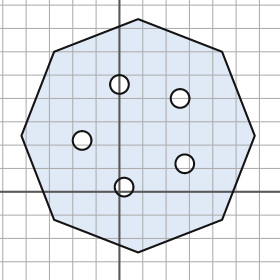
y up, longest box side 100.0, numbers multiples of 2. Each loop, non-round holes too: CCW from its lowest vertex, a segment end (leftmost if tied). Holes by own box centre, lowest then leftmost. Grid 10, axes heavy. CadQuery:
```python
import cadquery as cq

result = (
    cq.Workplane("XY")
    .moveTo(8.0, -26.0)
    .lineTo(44.0, -12.0)
    .lineTo(58.0, 24.0)
    .lineTo(44.0, 60.0)
    .lineTo(8.0, 74.0)
    .lineTo(-28.0, 60.0)
    .lineTo(-42.0, 24.0)
    .lineTo(-28.0, -12.0)
    .close()
    .moveTo(2.0, 2.0)
    .circle(4.0)
    .moveTo(28.0, 12.0)
    .circle(4.0)
    .moveTo(-16.0, 22.0)
    .circle(4.0)
    .moveTo(26.0, 40.0)
    .circle(4.0)
    .moveTo(0.0, 46.0)
    .circle(4.0)
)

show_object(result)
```